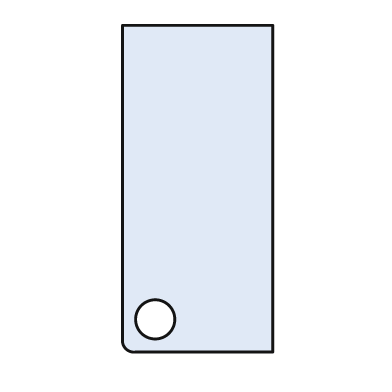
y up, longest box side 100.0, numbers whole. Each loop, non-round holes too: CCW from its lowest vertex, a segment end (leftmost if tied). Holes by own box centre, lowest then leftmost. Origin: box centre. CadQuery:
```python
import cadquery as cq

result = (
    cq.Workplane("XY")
    .moveTo(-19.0, -50.0)
    .lineTo(23.0, -50.0)
    .lineTo(23.0, 50.0)
    .lineTo(-23.0, 50.0)
    .lineTo(-23.0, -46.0)
    .threePointArc((-22.0, -49.0), (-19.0, -50.0))
    .close()
    .moveTo(-13.0, -40.0)
    .circle(6.0)
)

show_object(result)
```